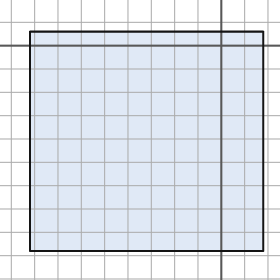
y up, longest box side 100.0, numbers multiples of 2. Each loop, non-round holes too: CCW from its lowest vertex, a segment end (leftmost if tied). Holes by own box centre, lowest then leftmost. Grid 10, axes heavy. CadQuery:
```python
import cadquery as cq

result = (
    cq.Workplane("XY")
    .moveTo(-82.0, -88.0)
    .lineTo(18.0, -88.0)
    .lineTo(18.0, 6.0)
    .lineTo(-82.0, 6.0)
    .close()
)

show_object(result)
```